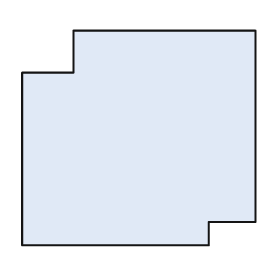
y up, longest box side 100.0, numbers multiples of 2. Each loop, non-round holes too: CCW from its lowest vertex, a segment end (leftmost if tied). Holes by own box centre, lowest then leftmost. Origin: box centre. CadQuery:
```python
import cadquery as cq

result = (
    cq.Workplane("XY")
    .moveTo(-50.0, -46.0)
    .lineTo(30.0, -46.0)
    .lineTo(30.0, -36.0)
    .lineTo(50.0, -36.0)
    .lineTo(50.0, 46.0)
    .lineTo(-28.0, 46.0)
    .lineTo(-28.0, 28.0)
    .lineTo(-50.0, 28.0)
    .close()
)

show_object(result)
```